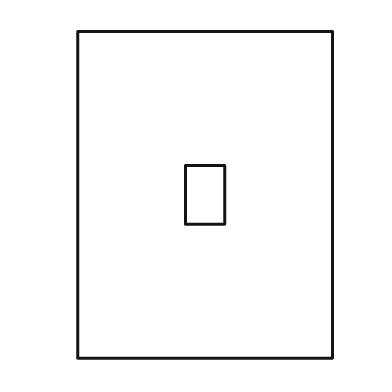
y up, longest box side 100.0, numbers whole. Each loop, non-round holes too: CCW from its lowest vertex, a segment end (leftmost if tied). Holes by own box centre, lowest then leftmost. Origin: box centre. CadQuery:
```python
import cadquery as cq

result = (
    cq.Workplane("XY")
    .moveTo(-39.0, -50.0)
    .lineTo(39.0, -50.0)
    .lineTo(39.0, 50.0)
    .lineTo(-39.0, 50.0)
    .close()
    .moveTo(-6.0, -9.0)
    .lineTo(6.0, -9.0)
    .lineTo(6.0, 9.0)
    .lineTo(-6.0, 9.0)
    .close()
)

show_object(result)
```